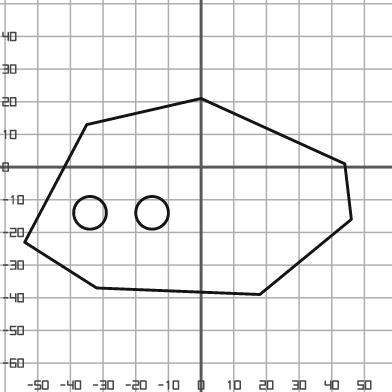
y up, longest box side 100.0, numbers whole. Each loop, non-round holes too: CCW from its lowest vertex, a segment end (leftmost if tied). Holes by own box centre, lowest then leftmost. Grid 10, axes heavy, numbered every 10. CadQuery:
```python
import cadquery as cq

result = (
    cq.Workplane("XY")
    .moveTo(18.0, -39.0)
    .lineTo(46.0, -16.0)
    .lineTo(44.0, 1.0)
    .lineTo(0.0, 21.0)
    .lineTo(-35.0, 13.0)
    .lineTo(-54.0, -23.0)
    .lineTo(-32.0, -37.0)
    .close()
    .moveTo(-34.0, -14.0)
    .circle(5.0)
    .moveTo(-15.0, -14.0)
    .circle(5.0)
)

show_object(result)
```